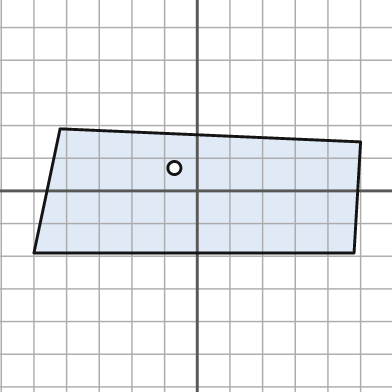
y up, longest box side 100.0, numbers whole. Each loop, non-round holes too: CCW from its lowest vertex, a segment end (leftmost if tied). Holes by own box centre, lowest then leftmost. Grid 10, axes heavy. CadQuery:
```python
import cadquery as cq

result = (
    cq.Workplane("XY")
    .moveTo(-50.0, -19.0)
    .lineTo(48.0, -19.0)
    .lineTo(50.0, 15.0)
    .lineTo(-42.0, 19.0)
    .close()
    .moveTo(-7.0, 7.0)
    .circle(2.0)
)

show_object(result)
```